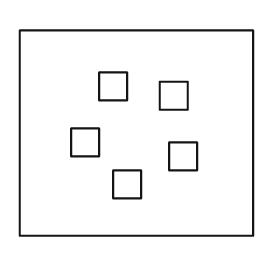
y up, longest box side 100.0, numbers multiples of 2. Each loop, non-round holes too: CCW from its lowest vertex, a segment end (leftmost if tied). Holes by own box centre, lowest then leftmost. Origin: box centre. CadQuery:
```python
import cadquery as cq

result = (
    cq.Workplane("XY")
    .moveTo(-50.0, -44.0)
    .lineTo(50.0, -44.0)
    .lineTo(50.0, 44.0)
    .lineTo(-50.0, 44.0)
    .close()
    .moveTo(-10.0, -28.0)
    .lineTo(2.0, -28.0)
    .lineTo(2.0, -16.0)
    .lineTo(-10.0, -16.0)
    .close()
    .moveTo(14.0, -16.0)
    .lineTo(26.0, -16.0)
    .lineTo(26.0, -4.0)
    .lineTo(14.0, -4.0)
    .close()
    .moveTo(-28.0, -10.0)
    .lineTo(-16.0, -10.0)
    .lineTo(-16.0, 2.0)
    .lineTo(-28.0, 2.0)
    .close()
    .moveTo(10.0, 10.0)
    .lineTo(22.0, 10.0)
    .lineTo(22.0, 22.0)
    .lineTo(10.0, 22.0)
    .close()
    .moveTo(-16.0, 14.0)
    .lineTo(-4.0, 14.0)
    .lineTo(-4.0, 26.0)
    .lineTo(-16.0, 26.0)
    .close()
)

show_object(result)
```